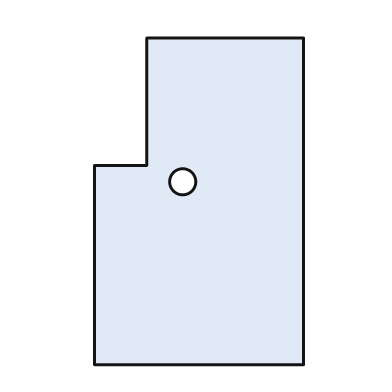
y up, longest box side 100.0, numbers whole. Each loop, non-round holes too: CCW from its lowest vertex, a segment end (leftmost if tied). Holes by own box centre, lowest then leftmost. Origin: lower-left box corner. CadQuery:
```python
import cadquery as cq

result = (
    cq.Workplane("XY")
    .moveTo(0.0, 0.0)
    .lineTo(64.0, 0.0)
    .lineTo(64.0, 100.0)
    .lineTo(16.0, 100.0)
    .lineTo(16.0, 61.0)
    .lineTo(0.0, 61.0)
    .close()
    .moveTo(27.0, 56.0)
    .circle(4.0)
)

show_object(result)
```